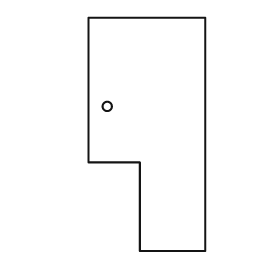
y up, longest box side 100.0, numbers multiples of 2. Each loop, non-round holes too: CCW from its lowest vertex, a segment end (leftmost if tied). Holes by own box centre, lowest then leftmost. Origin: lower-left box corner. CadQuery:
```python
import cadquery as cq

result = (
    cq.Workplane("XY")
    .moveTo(22.0, 0.0)
    .lineTo(50.0, 0.0)
    .lineTo(50.0, 100.0)
    .lineTo(0.0, 100.0)
    .lineTo(0.0, 38.0)
    .lineTo(22.0, 38.0)
    .close()
    .moveTo(8.0, 62.0)
    .circle(2.0)
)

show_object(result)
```